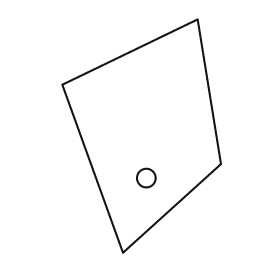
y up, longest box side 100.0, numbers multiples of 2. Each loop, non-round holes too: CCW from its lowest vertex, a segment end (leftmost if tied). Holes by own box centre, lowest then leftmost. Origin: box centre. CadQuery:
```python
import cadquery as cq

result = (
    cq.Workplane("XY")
    .moveTo(-8.0, -50.0)
    .lineTo(34.0, -12.0)
    .lineTo(24.0, 50.0)
    .lineTo(-34.0, 22.0)
    .close()
    .moveTo(2.0, -18.0)
    .circle(4.0)
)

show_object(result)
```